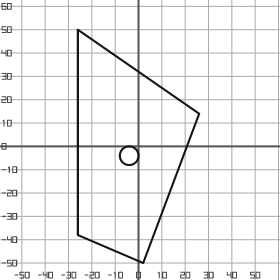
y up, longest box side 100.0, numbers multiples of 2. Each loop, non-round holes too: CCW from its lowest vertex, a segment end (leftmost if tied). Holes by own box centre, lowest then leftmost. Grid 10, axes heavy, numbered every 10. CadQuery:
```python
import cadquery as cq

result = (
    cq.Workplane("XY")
    .moveTo(2.0, -50.0)
    .lineTo(26.0, 14.0)
    .lineTo(-26.0, 50.0)
    .lineTo(-26.0, -38.0)
    .close()
    .moveTo(-4.0, -4.0)
    .circle(4.0)
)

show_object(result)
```